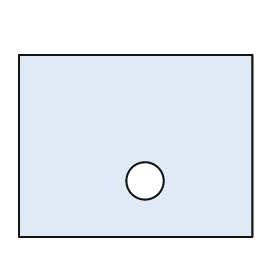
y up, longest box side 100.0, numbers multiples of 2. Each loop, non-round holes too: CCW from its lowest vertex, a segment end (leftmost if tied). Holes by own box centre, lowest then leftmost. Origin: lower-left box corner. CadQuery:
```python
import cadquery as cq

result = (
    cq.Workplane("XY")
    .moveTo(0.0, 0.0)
    .lineTo(100.0, 0.0)
    .lineTo(100.0, 78.0)
    .lineTo(0.0, 78.0)
    .close()
    .moveTo(54.0, 24.0)
    .circle(8.0)
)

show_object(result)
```